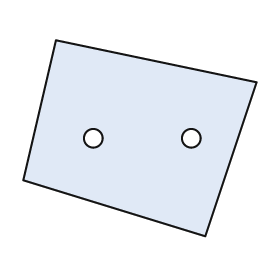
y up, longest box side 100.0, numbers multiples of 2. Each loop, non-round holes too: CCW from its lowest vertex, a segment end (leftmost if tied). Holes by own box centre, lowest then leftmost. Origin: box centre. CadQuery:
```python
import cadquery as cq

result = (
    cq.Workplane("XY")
    .moveTo(28.0, -42.0)
    .lineTo(50.0, 24.0)
    .lineTo(-36.0, 42.0)
    .lineTo(-50.0, -18.0)
    .close()
    .moveTo(-20.0, 0.0)
    .circle(4.0)
    .moveTo(22.0, 0.0)
    .circle(4.0)
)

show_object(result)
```